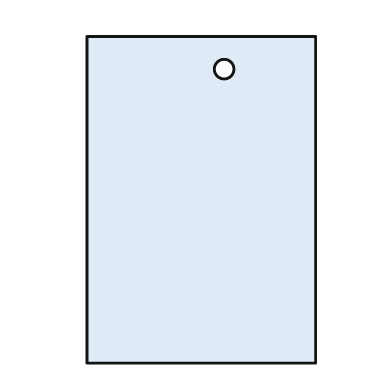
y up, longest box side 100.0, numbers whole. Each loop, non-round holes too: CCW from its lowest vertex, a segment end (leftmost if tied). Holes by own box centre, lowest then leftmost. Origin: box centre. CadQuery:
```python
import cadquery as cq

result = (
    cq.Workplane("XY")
    .moveTo(-35.0, -50.0)
    .lineTo(35.0, -50.0)
    .lineTo(35.0, 50.0)
    .lineTo(-35.0, 50.0)
    .close()
    .moveTo(7.0, 40.0)
    .circle(3.0)
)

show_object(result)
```